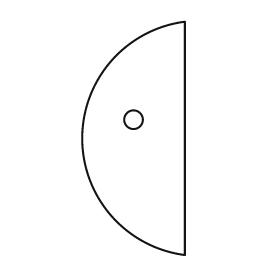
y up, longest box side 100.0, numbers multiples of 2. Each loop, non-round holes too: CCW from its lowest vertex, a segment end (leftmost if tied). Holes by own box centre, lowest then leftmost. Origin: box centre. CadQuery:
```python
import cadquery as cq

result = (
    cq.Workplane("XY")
    .moveTo(22.0, -50.0)
    .lineTo(22.0, 50.0)
    .threePointArc((-22.0, 0.0), (22.0, -50.0))
    .close()
    .moveTo(0.0, 8.0)
    .circle(4.0)
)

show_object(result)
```